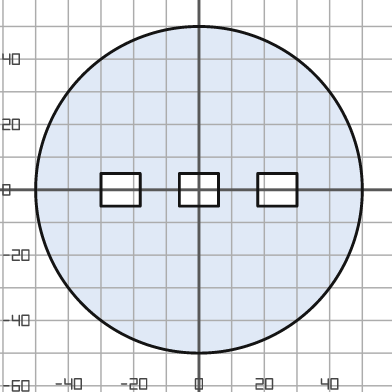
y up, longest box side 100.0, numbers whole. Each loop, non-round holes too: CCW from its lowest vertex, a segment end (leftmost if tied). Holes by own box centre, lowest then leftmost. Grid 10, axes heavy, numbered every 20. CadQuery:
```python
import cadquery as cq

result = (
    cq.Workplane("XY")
    .moveTo(0.0, 0.0)
    .circle(50.0)
    .moveTo(-30.0, -5.0)
    .lineTo(-18.0, -5.0)
    .lineTo(-18.0, 5.0)
    .lineTo(-30.0, 5.0)
    .close()
    .moveTo(-6.0, -5.0)
    .lineTo(6.0, -5.0)
    .lineTo(6.0, 5.0)
    .lineTo(-6.0, 5.0)
    .close()
    .moveTo(18.0, -5.0)
    .lineTo(30.0, -5.0)
    .lineTo(30.0, 5.0)
    .lineTo(18.0, 5.0)
    .close()
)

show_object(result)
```